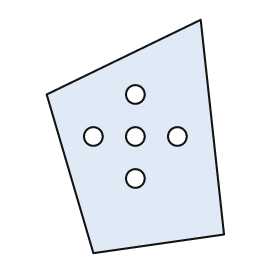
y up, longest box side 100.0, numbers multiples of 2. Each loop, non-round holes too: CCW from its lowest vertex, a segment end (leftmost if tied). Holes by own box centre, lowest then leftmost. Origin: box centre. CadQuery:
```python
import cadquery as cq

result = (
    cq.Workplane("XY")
    .moveTo(-18.0, -50.0)
    .lineTo(38.0, -42.0)
    .lineTo(28.0, 50.0)
    .lineTo(-38.0, 18.0)
    .close()
    .moveTo(0.0, -18.0)
    .circle(4.0)
    .moveTo(-18.0, 0.0)
    .circle(4.0)
    .moveTo(0.0, 0.0)
    .circle(4.0)
    .moveTo(18.0, 0.0)
    .circle(4.0)
    .moveTo(0.0, 18.0)
    .circle(4.0)
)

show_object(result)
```